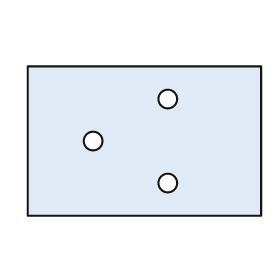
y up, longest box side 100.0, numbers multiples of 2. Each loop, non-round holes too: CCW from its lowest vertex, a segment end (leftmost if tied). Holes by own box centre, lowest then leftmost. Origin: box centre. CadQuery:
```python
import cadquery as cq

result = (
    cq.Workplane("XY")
    .moveTo(-50.0, -32.0)
    .lineTo(50.0, -32.0)
    .lineTo(50.0, 32.0)
    .lineTo(-50.0, 32.0)
    .close()
    .moveTo(10.0, -18.0)
    .circle(4.0)
    .moveTo(-22.0, 0.0)
    .circle(4.0)
    .moveTo(10.0, 18.0)
    .circle(4.0)
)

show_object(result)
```